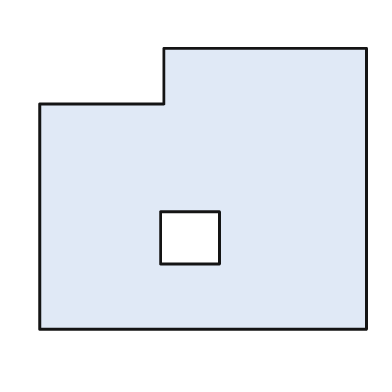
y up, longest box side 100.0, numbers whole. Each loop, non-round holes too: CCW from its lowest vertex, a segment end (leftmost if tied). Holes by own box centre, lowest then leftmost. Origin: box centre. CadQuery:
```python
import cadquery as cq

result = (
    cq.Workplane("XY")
    .moveTo(-50.0, -43.0)
    .lineTo(50.0, -43.0)
    .lineTo(50.0, 43.0)
    .lineTo(-12.0, 43.0)
    .lineTo(-12.0, 26.0)
    .lineTo(-50.0, 26.0)
    .close()
    .moveTo(-13.0, -23.0)
    .lineTo(5.0, -23.0)
    .lineTo(5.0, -7.0)
    .lineTo(-13.0, -7.0)
    .close()
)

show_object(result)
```